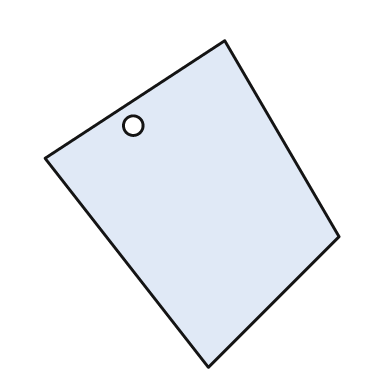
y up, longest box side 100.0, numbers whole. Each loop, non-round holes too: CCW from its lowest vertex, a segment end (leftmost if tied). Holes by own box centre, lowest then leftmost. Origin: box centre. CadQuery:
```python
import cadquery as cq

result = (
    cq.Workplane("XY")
    .moveTo(5.0, -50.0)
    .lineTo(45.0, -10.0)
    .lineTo(10.0, 50.0)
    .lineTo(-45.0, 14.0)
    .close()
    .moveTo(-18.0, 24.0)
    .circle(3.0)
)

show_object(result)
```